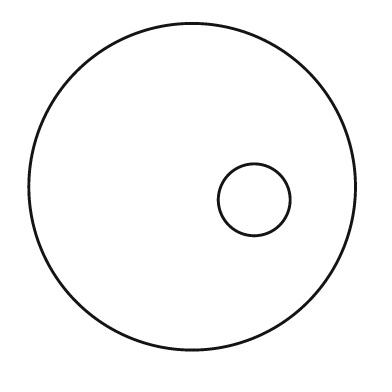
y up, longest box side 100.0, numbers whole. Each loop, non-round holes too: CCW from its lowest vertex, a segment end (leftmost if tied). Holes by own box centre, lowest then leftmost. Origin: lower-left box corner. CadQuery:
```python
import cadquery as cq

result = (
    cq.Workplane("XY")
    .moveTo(50.0, 50.0)
    .circle(50.0)
    .moveTo(69.0, 46.0)
    .circle(11.0)
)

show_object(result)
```